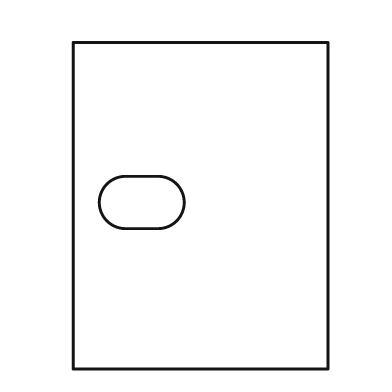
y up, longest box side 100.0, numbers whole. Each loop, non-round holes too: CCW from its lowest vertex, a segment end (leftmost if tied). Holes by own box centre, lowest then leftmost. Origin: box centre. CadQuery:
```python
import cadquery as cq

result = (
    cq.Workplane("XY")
    .moveTo(-39.0, -50.0)
    .lineTo(39.0, -50.0)
    .lineTo(39.0, 50.0)
    .lineTo(-39.0, 50.0)
    .close()
    .moveTo(-23.0, -7.0)
    .lineTo(-13.0, -7.0)
    .threePointArc((-5.0, 1.0), (-13.0, 9.0))
    .lineTo(-23.0, 9.0)
    .threePointArc((-31.0, 1.0), (-23.0, -7.0))
    .close()
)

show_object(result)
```